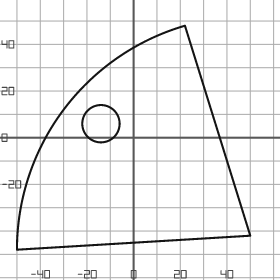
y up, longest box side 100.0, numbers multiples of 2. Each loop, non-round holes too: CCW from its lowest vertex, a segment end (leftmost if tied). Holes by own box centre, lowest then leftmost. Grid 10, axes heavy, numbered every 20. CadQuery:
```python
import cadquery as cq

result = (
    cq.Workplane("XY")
    .moveTo(-50.0, -48.0)
    .lineTo(50.0, -42.0)
    .lineTo(22.0, 48.0)
    .threePointArc((-30.0, 12.0), (-50.0, -48.0))
    .close()
    .moveTo(-14.0, 6.0)
    .circle(8.0)
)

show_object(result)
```